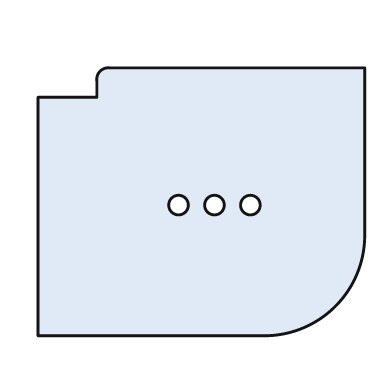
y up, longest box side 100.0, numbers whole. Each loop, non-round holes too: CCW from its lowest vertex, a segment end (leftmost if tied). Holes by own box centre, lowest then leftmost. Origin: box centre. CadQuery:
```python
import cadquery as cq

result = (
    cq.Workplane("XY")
    .moveTo(-50.0, -41.0)
    .lineTo(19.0, -41.0)
    .threePointArc((41.0, -32.0), (50.0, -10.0))
    .lineTo(50.0, 41.0)
    .lineTo(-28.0, 41.0)
    .threePointArc((-31.0, 40.0), (-32.0, 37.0))
    .lineTo(-32.0, 32.0)
    .lineTo(-50.0, 32.0)
    .close()
    .moveTo(-7.0, -1.0)
    .circle(3.0)
    .moveTo(4.0, -1.0)
    .circle(3.0)
    .moveTo(15.0, -1.0)
    .circle(3.0)
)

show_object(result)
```